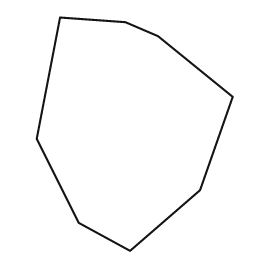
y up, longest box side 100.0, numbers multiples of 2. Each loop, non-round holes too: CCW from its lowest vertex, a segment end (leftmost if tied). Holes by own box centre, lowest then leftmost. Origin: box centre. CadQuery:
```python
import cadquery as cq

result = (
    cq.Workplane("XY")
    .moveTo(-2.0, -50.0)
    .lineTo(28.0, -24.0)
    .lineTo(42.0, 16.0)
    .lineTo(10.0, 42.0)
    .lineTo(-4.0, 48.0)
    .lineTo(-32.0, 50.0)
    .lineTo(-42.0, -2.0)
    .lineTo(-24.0, -38.0)
    .close()
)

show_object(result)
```